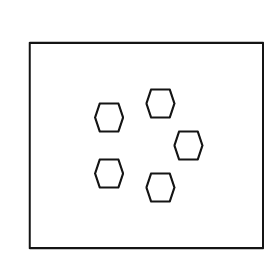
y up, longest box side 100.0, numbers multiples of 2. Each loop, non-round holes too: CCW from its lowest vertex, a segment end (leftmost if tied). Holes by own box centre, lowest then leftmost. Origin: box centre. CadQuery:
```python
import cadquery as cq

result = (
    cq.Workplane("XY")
    .moveTo(-50.0, -44.0)
    .lineTo(50.0, -44.0)
    .lineTo(50.0, 44.0)
    .lineTo(-50.0, 44.0)
    .close()
    .moveTo(2.0, -24.0)
    .lineTo(10.0, -24.0)
    .lineTo(12.0, -18.0)
    .lineTo(10.0, -12.0)
    .lineTo(2.0, -12.0)
    .lineTo(0.0, -18.0)
    .close()
    .moveTo(-20.0, -18.0)
    .lineTo(-12.0, -18.0)
    .lineTo(-10.0, -12.0)
    .lineTo(-12.0, -6.0)
    .lineTo(-20.0, -6.0)
    .lineTo(-22.0, -12.0)
    .close()
    .moveTo(14.0, -6.0)
    .lineTo(22.0, -6.0)
    .lineTo(24.0, 0.0)
    .lineTo(22.0, 6.0)
    .lineTo(14.0, 6.0)
    .lineTo(12.0, 0.0)
    .close()
    .moveTo(-20.0, 6.0)
    .lineTo(-12.0, 6.0)
    .lineTo(-10.0, 12.0)
    .lineTo(-12.0, 18.0)
    .lineTo(-20.0, 18.0)
    .lineTo(-22.0, 12.0)
    .close()
    .moveTo(2.0, 12.0)
    .lineTo(10.0, 12.0)
    .lineTo(12.0, 18.0)
    .lineTo(10.0, 24.0)
    .lineTo(2.0, 24.0)
    .lineTo(0.0, 18.0)
    .close()
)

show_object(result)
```